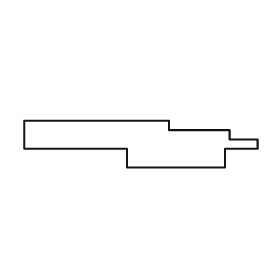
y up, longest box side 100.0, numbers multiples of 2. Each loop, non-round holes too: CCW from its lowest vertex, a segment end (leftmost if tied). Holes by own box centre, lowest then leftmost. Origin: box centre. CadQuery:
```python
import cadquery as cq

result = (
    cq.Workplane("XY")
    .moveTo(-6.0, -10.0)
    .lineTo(36.0, -10.0)
    .lineTo(36.0, -2.0)
    .lineTo(50.0, -2.0)
    .lineTo(50.0, 2.0)
    .lineTo(38.0, 2.0)
    .lineTo(38.0, 6.0)
    .lineTo(12.0, 6.0)
    .lineTo(12.0, 10.0)
    .lineTo(-50.0, 10.0)
    .lineTo(-50.0, -2.0)
    .lineTo(-6.0, -2.0)
    .close()
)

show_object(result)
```